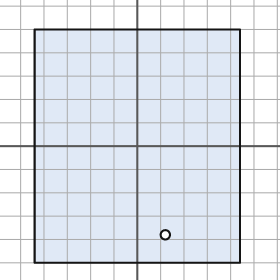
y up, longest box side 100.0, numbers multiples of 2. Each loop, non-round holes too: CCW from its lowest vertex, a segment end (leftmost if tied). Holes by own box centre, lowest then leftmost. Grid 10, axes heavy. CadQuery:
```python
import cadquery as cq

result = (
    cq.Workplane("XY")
    .moveTo(-44.0, -50.0)
    .lineTo(44.0, -50.0)
    .lineTo(44.0, 50.0)
    .lineTo(-44.0, 50.0)
    .close()
    .moveTo(12.0, -38.0)
    .circle(2.0)
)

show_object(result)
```